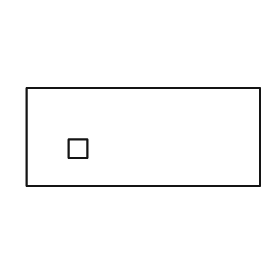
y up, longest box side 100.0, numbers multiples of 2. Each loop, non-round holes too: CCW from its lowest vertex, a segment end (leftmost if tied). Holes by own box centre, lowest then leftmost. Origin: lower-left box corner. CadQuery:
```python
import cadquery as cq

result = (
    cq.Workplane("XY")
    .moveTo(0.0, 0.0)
    .lineTo(100.0, 0.0)
    .lineTo(100.0, 42.0)
    .lineTo(0.0, 42.0)
    .close()
    .moveTo(18.0, 12.0)
    .lineTo(26.0, 12.0)
    .lineTo(26.0, 20.0)
    .lineTo(18.0, 20.0)
    .close()
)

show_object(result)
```